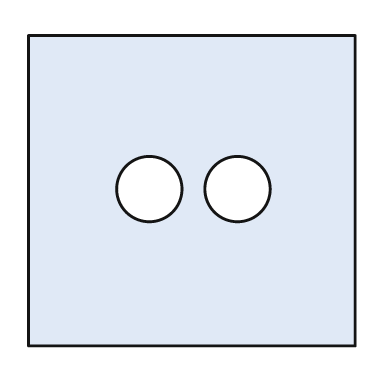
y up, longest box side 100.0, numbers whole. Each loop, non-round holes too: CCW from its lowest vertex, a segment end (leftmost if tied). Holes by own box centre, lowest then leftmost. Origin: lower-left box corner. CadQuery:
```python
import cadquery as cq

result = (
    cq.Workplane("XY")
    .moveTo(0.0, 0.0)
    .lineTo(100.0, 0.0)
    .lineTo(100.0, 95.0)
    .lineTo(0.0, 95.0)
    .close()
    .moveTo(37.0, 48.0)
    .circle(10.0)
    .moveTo(64.0, 48.0)
    .circle(10.0)
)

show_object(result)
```